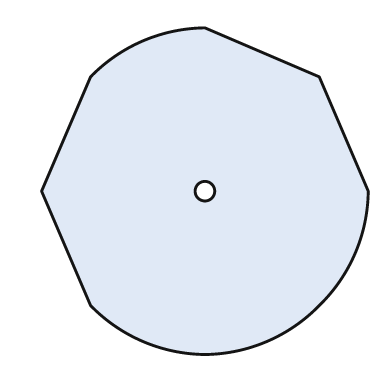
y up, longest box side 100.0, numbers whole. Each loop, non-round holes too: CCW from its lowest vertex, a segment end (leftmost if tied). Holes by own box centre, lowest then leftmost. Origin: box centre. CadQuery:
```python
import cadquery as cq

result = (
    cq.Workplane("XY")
    .moveTo(0.0, -50.0)
    .threePointArc((19.0, -46.0), (35.0, -35.0))
    .threePointArc((46.0, -19.0), (50.0, 0.0))
    .lineTo(35.0, 35.0)
    .lineTo(0.0, 50.0)
    .threePointArc((-19.0, 46.0), (-35.0, 35.0))
    .lineTo(-50.0, 0.0)
    .lineTo(-35.0, -35.0)
    .threePointArc((-19.0, -46.0), (0.0, -50.0))
    .close()
    .moveTo(0.0, 0.0)
    .circle(3.0)
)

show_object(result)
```